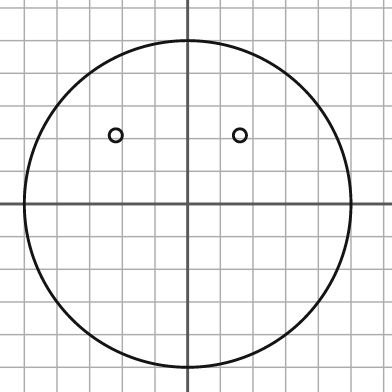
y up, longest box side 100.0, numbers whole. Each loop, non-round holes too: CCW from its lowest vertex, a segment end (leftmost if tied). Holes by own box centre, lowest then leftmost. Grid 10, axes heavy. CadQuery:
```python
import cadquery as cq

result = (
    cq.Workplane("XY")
    .moveTo(0.0, 0.0)
    .circle(50.0)
    .moveTo(-22.0, 21.0)
    .circle(2.0)
    .moveTo(16.0, 21.0)
    .circle(2.0)
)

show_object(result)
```